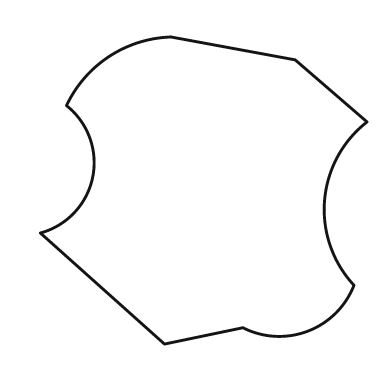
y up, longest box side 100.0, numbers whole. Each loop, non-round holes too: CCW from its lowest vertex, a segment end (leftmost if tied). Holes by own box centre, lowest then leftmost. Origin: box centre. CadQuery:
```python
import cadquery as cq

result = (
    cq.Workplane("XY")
    .moveTo(-12.0, -47.0)
    .lineTo(12.0, -42.0)
    .threePointArc((32.0, -43.0), (46.0, -29.0))
    .threePointArc((37.0, -3.0), (50.0, 21.0))
    .lineTo(28.0, 40.0)
    .lineTo(-10.0, 47.0)
    .threePointArc((-29.0, 41.0), (-42.0, 26.0))
    .threePointArc((-34.0, 4.0), (-50.0, -13.0))
    .close()
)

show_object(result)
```